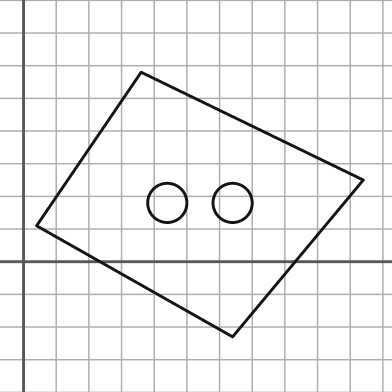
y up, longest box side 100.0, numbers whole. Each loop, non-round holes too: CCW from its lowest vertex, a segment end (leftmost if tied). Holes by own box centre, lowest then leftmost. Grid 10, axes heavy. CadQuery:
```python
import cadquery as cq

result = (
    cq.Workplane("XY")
    .moveTo(64.0, -23.0)
    .lineTo(104.0, 25.0)
    .lineTo(36.0, 58.0)
    .lineTo(4.0, 11.0)
    .close()
    .moveTo(44.0, 18.0)
    .circle(6.0)
    .moveTo(64.0, 18.0)
    .circle(6.0)
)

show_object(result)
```